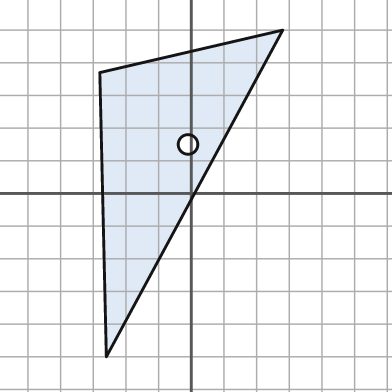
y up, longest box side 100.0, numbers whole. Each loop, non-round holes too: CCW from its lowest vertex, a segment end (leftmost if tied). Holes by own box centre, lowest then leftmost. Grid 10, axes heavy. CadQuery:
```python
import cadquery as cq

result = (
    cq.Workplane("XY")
    .moveTo(-26.0, -50.0)
    .lineTo(28.0, 50.0)
    .lineTo(-28.0, 37.0)
    .close()
    .moveTo(-1.0, 15.0)
    .circle(3.0)
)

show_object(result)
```